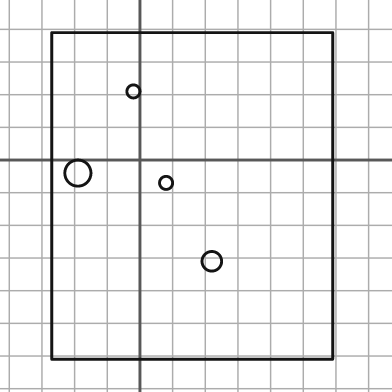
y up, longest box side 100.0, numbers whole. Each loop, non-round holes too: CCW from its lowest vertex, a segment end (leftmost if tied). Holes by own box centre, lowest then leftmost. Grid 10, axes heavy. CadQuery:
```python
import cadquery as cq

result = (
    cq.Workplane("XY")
    .moveTo(-27.0, -61.0)
    .lineTo(59.0, -61.0)
    .lineTo(59.0, 39.0)
    .lineTo(-27.0, 39.0)
    .close()
    .moveTo(22.0, -31.0)
    .circle(3.0)
    .moveTo(8.0, -7.0)
    .circle(2.0)
    .moveTo(-19.0, -4.0)
    .circle(4.0)
    .moveTo(-2.0, 21.0)
    .circle(2.0)
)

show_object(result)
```